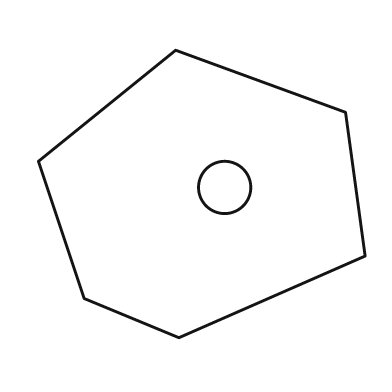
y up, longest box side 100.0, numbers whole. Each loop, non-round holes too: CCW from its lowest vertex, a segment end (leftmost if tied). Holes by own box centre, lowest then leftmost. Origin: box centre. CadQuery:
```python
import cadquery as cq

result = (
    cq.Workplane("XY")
    .moveTo(-7.0, -44.0)
    .lineTo(50.0, -19.0)
    .lineTo(44.0, 25.0)
    .lineTo(-8.0, 44.0)
    .lineTo(-50.0, 10.0)
    .lineTo(-36.0, -32.0)
    .close()
    .moveTo(7.0, 2.0)
    .circle(8.0)
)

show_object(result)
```